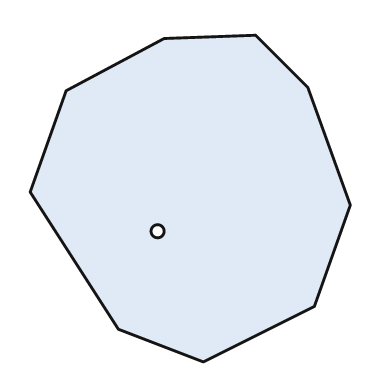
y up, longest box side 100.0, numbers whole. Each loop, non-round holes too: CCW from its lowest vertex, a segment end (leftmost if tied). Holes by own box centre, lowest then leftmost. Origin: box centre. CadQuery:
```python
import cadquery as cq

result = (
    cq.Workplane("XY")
    .moveTo(4.0, -50.0)
    .lineTo(38.0, -33.0)
    .lineTo(49.0, -2.0)
    .lineTo(36.0, 34.0)
    .lineTo(20.0, 50.0)
    .lineTo(-8.0, 49.0)
    .lineTo(-38.0, 33.0)
    .lineTo(-49.0, 2.0)
    .lineTo(-22.0, -40.0)
    .close()
    .moveTo(-10.0, -10.0)
    .circle(2.0)
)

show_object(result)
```